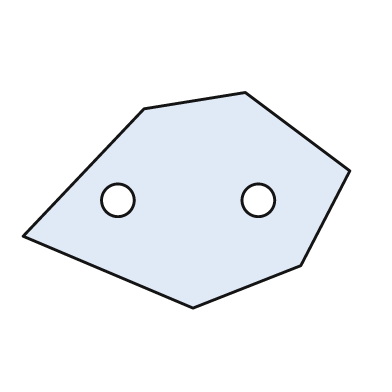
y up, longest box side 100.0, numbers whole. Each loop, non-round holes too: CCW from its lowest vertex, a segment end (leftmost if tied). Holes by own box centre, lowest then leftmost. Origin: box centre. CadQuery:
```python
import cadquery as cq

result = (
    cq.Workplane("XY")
    .moveTo(2.0, -33.0)
    .lineTo(35.0, -20.0)
    .lineTo(50.0, 9.0)
    .lineTo(18.0, 33.0)
    .lineTo(-13.0, 28.0)
    .lineTo(-50.0, -11.0)
    .close()
    .moveTo(-21.0, 0.0)
    .circle(5.0)
    .moveTo(22.0, 0.0)
    .circle(5.0)
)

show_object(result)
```